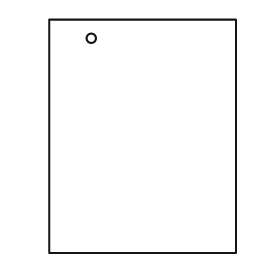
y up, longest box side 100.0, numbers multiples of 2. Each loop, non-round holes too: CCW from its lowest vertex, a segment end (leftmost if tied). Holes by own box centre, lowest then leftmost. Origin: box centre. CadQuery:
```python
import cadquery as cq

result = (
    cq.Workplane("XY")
    .moveTo(-40.0, -50.0)
    .lineTo(40.0, -50.0)
    .lineTo(40.0, 50.0)
    .lineTo(-40.0, 50.0)
    .close()
    .moveTo(-22.0, 42.0)
    .circle(2.0)
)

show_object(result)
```